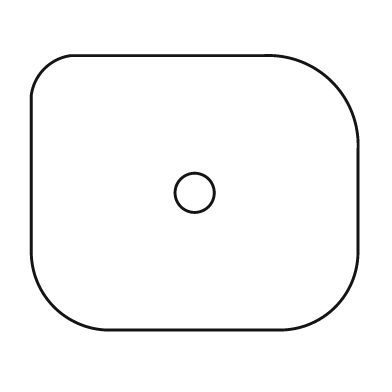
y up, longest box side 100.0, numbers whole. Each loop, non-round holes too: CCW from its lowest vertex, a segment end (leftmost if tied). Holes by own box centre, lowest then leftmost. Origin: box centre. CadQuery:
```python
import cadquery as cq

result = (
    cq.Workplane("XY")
    .moveTo(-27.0, -42.0)
    .lineTo(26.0, -42.0)
    .threePointArc((43.0, -35.0), (50.0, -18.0))
    .lineTo(50.0, 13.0)
    .threePointArc((42.0, 34.0), (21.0, 42.0))
    .lineTo(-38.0, 42.0)
    .threePointArc((-46.0, 38.0), (-50.0, 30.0))
    .lineTo(-50.0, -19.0)
    .threePointArc((-43.0, -35.0), (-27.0, -42.0))
    .close()
    .moveTo(0.0, 0.0)
    .circle(6.0)
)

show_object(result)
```